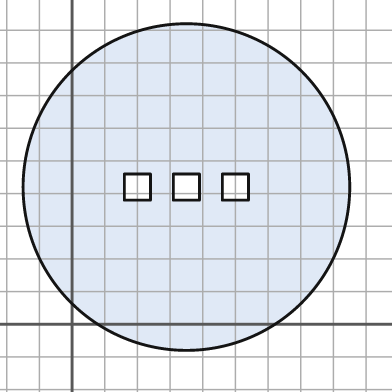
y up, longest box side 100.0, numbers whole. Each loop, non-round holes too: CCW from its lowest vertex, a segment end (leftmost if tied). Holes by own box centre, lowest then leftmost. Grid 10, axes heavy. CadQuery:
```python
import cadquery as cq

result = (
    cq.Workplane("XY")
    .moveTo(35.0, 42.0)
    .circle(50.0)
    .moveTo(16.0, 38.0)
    .lineTo(24.0, 38.0)
    .lineTo(24.0, 46.0)
    .lineTo(16.0, 46.0)
    .close()
    .moveTo(31.0, 38.0)
    .lineTo(39.0, 38.0)
    .lineTo(39.0, 46.0)
    .lineTo(31.0, 46.0)
    .close()
    .moveTo(46.0, 38.0)
    .lineTo(54.0, 38.0)
    .lineTo(54.0, 46.0)
    .lineTo(46.0, 46.0)
    .close()
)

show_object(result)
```